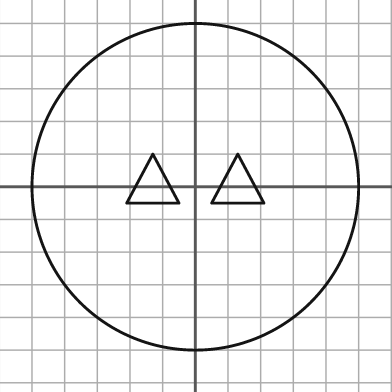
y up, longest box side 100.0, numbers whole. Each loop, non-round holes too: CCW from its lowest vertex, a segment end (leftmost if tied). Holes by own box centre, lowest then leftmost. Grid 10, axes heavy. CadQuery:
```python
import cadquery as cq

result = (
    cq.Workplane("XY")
    .moveTo(0.0, 0.0)
    .circle(50.0)
    .moveTo(-21.0, -5.0)
    .lineTo(-5.0, -5.0)
    .lineTo(-13.0, 10.0)
    .close()
    .moveTo(5.0, -5.0)
    .lineTo(21.0, -5.0)
    .lineTo(13.0, 10.0)
    .close()
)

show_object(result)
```